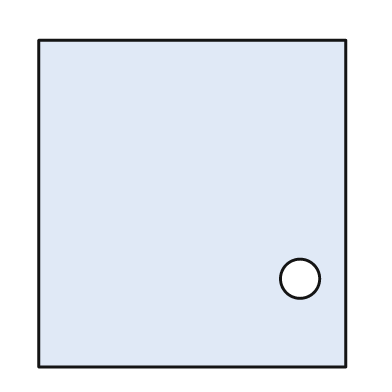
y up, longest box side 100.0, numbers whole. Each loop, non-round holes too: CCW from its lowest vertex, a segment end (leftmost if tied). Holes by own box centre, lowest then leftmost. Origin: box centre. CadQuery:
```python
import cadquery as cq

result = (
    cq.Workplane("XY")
    .moveTo(-47.0, -50.0)
    .lineTo(47.0, -50.0)
    .lineTo(47.0, 50.0)
    .lineTo(-47.0, 50.0)
    .close()
    .moveTo(33.0, -23.0)
    .circle(6.0)
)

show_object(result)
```